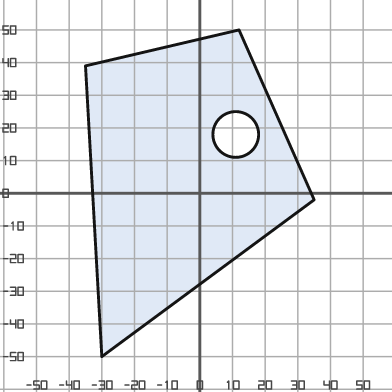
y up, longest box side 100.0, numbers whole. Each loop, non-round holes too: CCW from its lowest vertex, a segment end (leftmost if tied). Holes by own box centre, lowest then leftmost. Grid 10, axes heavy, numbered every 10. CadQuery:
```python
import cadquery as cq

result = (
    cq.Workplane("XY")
    .moveTo(-30.0, -50.0)
    .lineTo(35.0, -2.0)
    .lineTo(12.0, 50.0)
    .lineTo(-35.0, 39.0)
    .close()
    .moveTo(11.0, 18.0)
    .circle(7.0)
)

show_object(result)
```